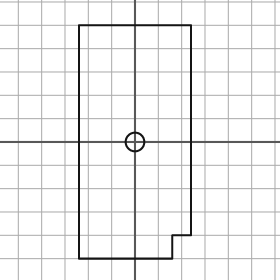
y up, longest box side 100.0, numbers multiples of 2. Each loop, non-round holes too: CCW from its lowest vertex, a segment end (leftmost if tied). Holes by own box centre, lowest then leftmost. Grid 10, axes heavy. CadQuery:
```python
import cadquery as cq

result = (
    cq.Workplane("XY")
    .moveTo(-24.0, -50.0)
    .lineTo(16.0, -50.0)
    .lineTo(16.0, -40.0)
    .lineTo(24.0, -40.0)
    .lineTo(24.0, 50.0)
    .lineTo(-24.0, 50.0)
    .close()
    .moveTo(0.0, 0.0)
    .circle(4.0)
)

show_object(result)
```